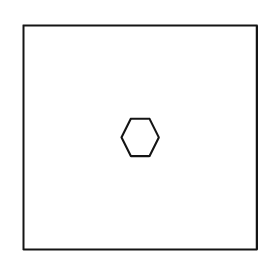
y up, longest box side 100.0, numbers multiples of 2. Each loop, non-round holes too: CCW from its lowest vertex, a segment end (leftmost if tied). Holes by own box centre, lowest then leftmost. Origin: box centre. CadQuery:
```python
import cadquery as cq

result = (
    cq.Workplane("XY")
    .moveTo(-50.0, -48.0)
    .lineTo(50.0, -48.0)
    .lineTo(50.0, 48.0)
    .lineTo(-50.0, 48.0)
    .close()
    .moveTo(-4.0, -8.0)
    .lineTo(4.0, -8.0)
    .lineTo(8.0, 0.0)
    .lineTo(4.0, 8.0)
    .lineTo(-4.0, 8.0)
    .lineTo(-8.0, 0.0)
    .close()
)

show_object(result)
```